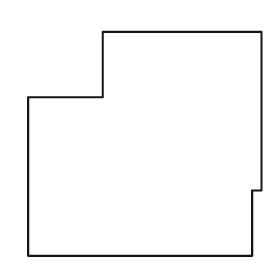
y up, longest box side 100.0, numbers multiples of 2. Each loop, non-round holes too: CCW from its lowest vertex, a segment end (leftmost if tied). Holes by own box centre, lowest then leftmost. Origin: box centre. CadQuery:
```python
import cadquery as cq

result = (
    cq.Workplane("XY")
    .moveTo(-50.0, -48.0)
    .lineTo(46.0, -48.0)
    .lineTo(46.0, -20.0)
    .lineTo(50.0, -20.0)
    .lineTo(50.0, 48.0)
    .lineTo(-18.0, 48.0)
    .lineTo(-18.0, 20.0)
    .lineTo(-50.0, 20.0)
    .close()
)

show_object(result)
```